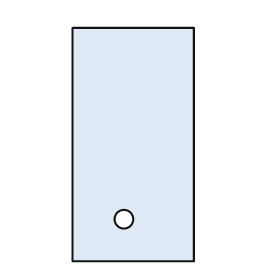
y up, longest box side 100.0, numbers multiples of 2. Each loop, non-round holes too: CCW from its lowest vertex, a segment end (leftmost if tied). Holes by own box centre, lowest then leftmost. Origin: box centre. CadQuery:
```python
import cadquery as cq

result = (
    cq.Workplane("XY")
    .moveTo(-26.0, -50.0)
    .lineTo(26.0, -50.0)
    .lineTo(26.0, 50.0)
    .lineTo(-26.0, 50.0)
    .close()
    .moveTo(-4.0, -32.0)
    .circle(4.0)
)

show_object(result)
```